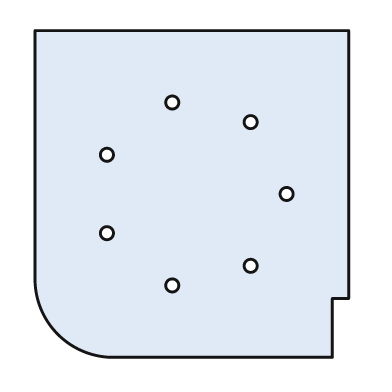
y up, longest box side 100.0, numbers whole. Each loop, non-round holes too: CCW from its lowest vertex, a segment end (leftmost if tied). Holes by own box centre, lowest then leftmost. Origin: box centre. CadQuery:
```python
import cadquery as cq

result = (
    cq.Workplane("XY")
    .moveTo(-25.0, -50.0)
    .lineTo(43.0, -50.0)
    .lineTo(43.0, -32.0)
    .lineTo(48.0, -32.0)
    .lineTo(48.0, 50.0)
    .lineTo(-48.0, 50.0)
    .lineTo(-48.0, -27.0)
    .threePointArc((-41.0, -43.0), (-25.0, -50.0))
    .close()
    .moveTo(-6.0, -28.0)
    .circle(2.0)
    .moveTo(18.0, -22.0)
    .circle(2.0)
    .moveTo(-26.0, -12.0)
    .circle(2.0)
    .moveTo(29.0, 0.0)
    .circle(2.0)
    .moveTo(-26.0, 12.0)
    .circle(2.0)
    .moveTo(18.0, 22.0)
    .circle(2.0)
    .moveTo(-6.0, 28.0)
    .circle(2.0)
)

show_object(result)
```